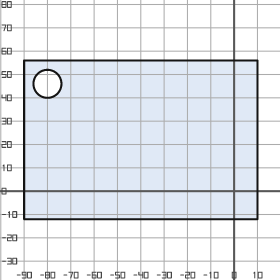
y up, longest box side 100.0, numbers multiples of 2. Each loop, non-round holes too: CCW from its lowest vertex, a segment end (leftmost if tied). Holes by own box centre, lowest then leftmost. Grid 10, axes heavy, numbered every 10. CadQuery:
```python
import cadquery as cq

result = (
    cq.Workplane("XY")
    .moveTo(-90.0, -12.0)
    .lineTo(10.0, -12.0)
    .lineTo(10.0, 56.0)
    .lineTo(-90.0, 56.0)
    .close()
    .moveTo(-80.0, 46.0)
    .circle(6.0)
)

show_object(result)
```